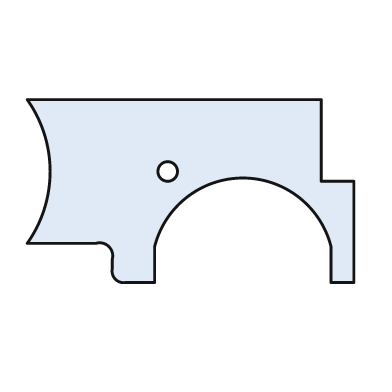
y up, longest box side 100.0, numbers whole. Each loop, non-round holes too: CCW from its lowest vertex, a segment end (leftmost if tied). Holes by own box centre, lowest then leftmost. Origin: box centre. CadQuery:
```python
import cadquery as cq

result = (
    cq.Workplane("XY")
    .moveTo(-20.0, -28.0)
    .lineTo(-11.0, -28.0)
    .lineTo(-11.0, -17.0)
    .threePointArc((16.0, 4.0), (43.0, -17.0))
    .lineTo(43.0, -28.0)
    .lineTo(50.0, -28.0)
    .lineTo(50.0, 3.0)
    .lineTo(40.0, 3.0)
    .lineTo(40.0, 28.0)
    .lineTo(-50.0, 28.0)
    .threePointArc((-43.0, 6.0), (-50.0, -16.0))
    .lineTo(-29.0, -16.0)
    .threePointArc((-25.0, -17.0), (-24.0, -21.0))
    .lineTo(-24.0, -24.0)
    .threePointArc((-23.0, -27.0), (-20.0, -28.0))
    .close()
    .moveTo(-7.0, 6.0)
    .circle(3.0)
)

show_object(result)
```